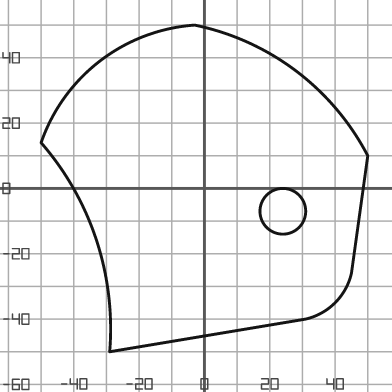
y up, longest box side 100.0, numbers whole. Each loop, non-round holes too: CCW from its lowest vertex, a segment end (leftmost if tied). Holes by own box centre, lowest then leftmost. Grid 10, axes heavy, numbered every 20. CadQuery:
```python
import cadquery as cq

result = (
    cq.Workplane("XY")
    .moveTo(-29.0, -50.0)
    .lineTo(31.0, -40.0)
    .threePointArc((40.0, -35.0), (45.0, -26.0))
    .lineTo(50.0, 10.0)
    .threePointArc((28.0, 36.0), (-3.0, 50.0))
    .threePointArc((-32.0, 39.0), (-50.0, 14.0))
    .threePointArc((-33.0, -16.0), (-29.0, -50.0))
    .close()
    .moveTo(24.0, -7.0)
    .circle(7.0)
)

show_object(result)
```